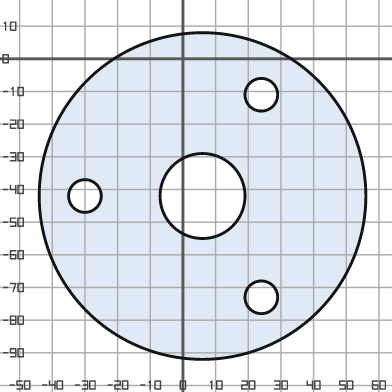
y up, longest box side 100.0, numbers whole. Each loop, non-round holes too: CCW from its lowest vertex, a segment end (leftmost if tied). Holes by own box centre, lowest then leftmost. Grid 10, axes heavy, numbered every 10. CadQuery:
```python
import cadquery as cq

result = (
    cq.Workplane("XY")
    .moveTo(6.0, -42.0)
    .circle(50.0)
    .moveTo(24.0, -73.0)
    .circle(5.0)
    .moveTo(-30.0, -42.0)
    .circle(5.0)
    .moveTo(6.0, -42.0)
    .circle(13.0)
    .moveTo(24.0, -11.0)
    .circle(5.0)
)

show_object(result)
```